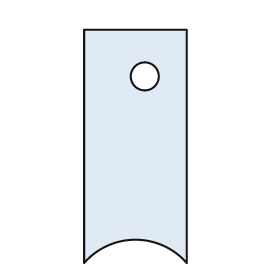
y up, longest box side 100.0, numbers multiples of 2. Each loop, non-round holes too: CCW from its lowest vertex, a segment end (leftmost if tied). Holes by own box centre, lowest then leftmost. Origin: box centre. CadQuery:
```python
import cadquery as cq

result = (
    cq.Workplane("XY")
    .moveTo(-22.0, -50.0)
    .threePointArc((0.0, -40.0), (22.0, -50.0))
    .lineTo(22.0, 50.0)
    .lineTo(-22.0, 50.0)
    .close()
    .moveTo(4.0, 30.0)
    .circle(6.0)
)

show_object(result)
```